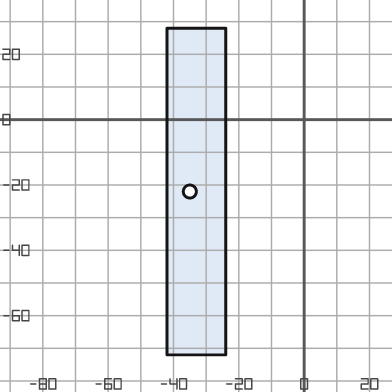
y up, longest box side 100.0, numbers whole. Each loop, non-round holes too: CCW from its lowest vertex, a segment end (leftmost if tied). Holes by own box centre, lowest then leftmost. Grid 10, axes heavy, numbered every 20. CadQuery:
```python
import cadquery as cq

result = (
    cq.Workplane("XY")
    .moveTo(-42.0, -72.0)
    .lineTo(-24.0, -72.0)
    .lineTo(-24.0, 28.0)
    .lineTo(-42.0, 28.0)
    .close()
    .moveTo(-35.0, -22.0)
    .circle(2.0)
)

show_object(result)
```